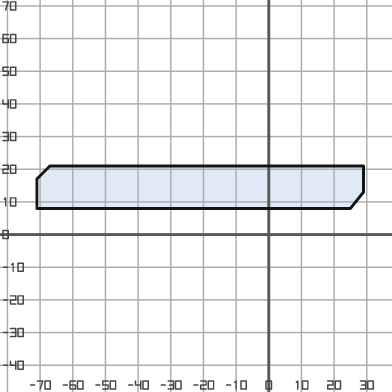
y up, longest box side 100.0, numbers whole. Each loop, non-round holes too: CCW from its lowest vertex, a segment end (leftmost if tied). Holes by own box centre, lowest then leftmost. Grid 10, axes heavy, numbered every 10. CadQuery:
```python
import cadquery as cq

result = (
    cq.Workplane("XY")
    .moveTo(-71.0, 8.0)
    .lineTo(25.0, 8.0)
    .lineTo(29.0, 13.0)
    .lineTo(29.0, 21.0)
    .lineTo(-67.0, 21.0)
    .lineTo(-71.0, 17.0)
    .close()
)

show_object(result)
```